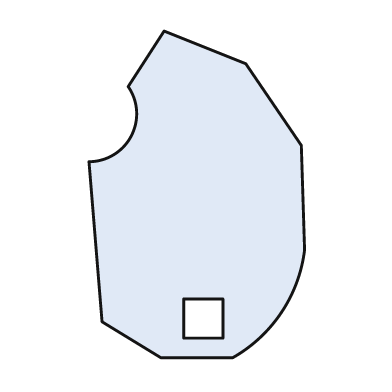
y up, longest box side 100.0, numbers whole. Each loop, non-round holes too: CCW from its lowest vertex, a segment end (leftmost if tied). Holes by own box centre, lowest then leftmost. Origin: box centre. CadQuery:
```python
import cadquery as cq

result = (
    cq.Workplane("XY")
    .moveTo(-11.0, -50.0)
    .lineTo(11.0, -50.0)
    .threePointArc((26.0, -36.0), (33.0, -17.0))
    .lineTo(32.0, 15.0)
    .lineTo(15.0, 40.0)
    .lineTo(-10.0, 50.0)
    .lineTo(-21.0, 33.0)
    .threePointArc((-20.0, 18.0), (-33.0, 10.0))
    .lineTo(-29.0, -39.0)
    .close()
    .moveTo(-4.0, -44.0)
    .lineTo(8.0, -44.0)
    .lineTo(8.0, -32.0)
    .lineTo(-4.0, -32.0)
    .close()
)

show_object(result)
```